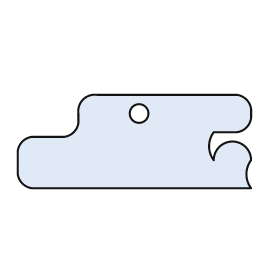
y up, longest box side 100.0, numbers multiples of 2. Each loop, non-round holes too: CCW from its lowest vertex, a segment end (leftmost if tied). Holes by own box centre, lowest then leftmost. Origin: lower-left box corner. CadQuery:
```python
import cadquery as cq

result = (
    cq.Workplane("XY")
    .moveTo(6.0, 0.0)
    .lineTo(100.0, 0.0)
    .threePointArc((98.0, 6.0), (100.0, 12.0))
    .threePointArc((92.0, 20.0), (84.0, 12.0))
    .threePointArc((82.0, 18.0), (84.0, 24.0))
    .lineTo(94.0, 24.0)
    .threePointArc((98.0, 26.0), (100.0, 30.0))
    .lineTo(100.0, 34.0)
    .threePointArc((98.0, 38.0), (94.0, 40.0))
    .lineTo(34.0, 40.0)
    .threePointArc((28.0, 38.0), (26.0, 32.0))
    .lineTo(26.0, 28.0)
    .threePointArc((24.0, 24.0), (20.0, 22.0))
    .lineTo(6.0, 22.0)
    .threePointArc((2.0, 20.0), (0.0, 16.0))
    .lineTo(0.0, 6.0)
    .threePointArc((2.0, 2.0), (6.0, 0.0))
    .close()
    .moveTo(52.0, 32.0)
    .circle(4.0)
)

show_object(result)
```